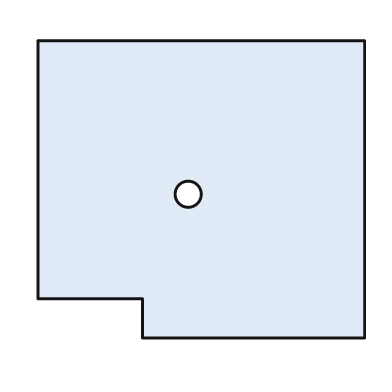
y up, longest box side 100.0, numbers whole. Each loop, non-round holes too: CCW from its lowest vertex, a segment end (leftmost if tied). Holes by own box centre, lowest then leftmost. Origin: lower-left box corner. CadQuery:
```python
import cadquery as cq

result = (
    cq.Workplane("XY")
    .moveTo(32.0, 0.0)
    .lineTo(100.0, 0.0)
    .lineTo(100.0, 91.0)
    .lineTo(0.0, 91.0)
    .lineTo(0.0, 12.0)
    .lineTo(32.0, 12.0)
    .close()
    .moveTo(46.0, 44.0)
    .circle(4.0)
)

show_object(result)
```